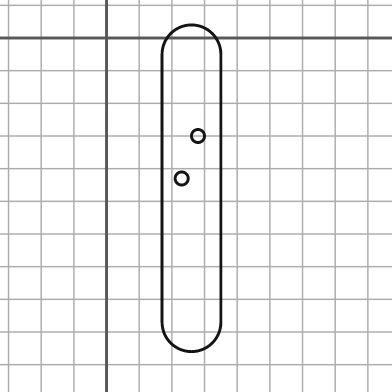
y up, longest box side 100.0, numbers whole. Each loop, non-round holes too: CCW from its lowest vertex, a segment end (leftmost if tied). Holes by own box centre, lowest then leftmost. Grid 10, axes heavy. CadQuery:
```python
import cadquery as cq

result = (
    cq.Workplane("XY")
    .moveTo(17.0, -87.0)
    .threePointArc((26.0, -96.0), (35.0, -87.0))
    .lineTo(35.0, -5.0)
    .threePointArc((26.0, 4.0), (17.0, -5.0))
    .close()
    .moveTo(23.0, -43.0)
    .circle(2.0)
    .moveTo(28.0, -30.0)
    .circle(2.0)
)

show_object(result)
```